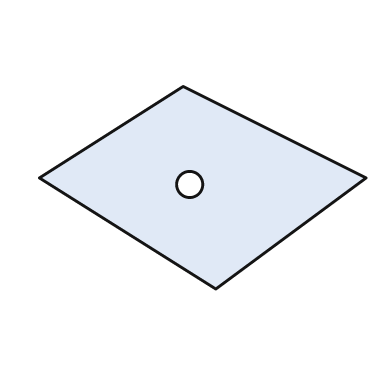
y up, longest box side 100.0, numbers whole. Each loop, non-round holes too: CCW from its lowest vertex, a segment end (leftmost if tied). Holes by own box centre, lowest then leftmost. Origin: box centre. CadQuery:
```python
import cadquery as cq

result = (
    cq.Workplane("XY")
    .moveTo(4.0, -31.0)
    .lineTo(50.0, 3.0)
    .lineTo(-6.0, 31.0)
    .lineTo(-50.0, 3.0)
    .close()
    .moveTo(-4.0, 1.0)
    .circle(4.0)
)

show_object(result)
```